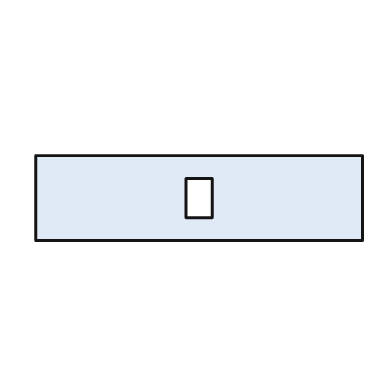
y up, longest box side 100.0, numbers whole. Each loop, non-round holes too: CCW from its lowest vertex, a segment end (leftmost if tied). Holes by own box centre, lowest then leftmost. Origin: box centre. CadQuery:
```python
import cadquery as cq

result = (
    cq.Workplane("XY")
    .moveTo(-50.0, -13.0)
    .lineTo(50.0, -13.0)
    .lineTo(50.0, 13.0)
    .lineTo(-50.0, 13.0)
    .close()
    .moveTo(-4.0, -6.0)
    .lineTo(4.0, -6.0)
    .lineTo(4.0, 6.0)
    .lineTo(-4.0, 6.0)
    .close()
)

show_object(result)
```